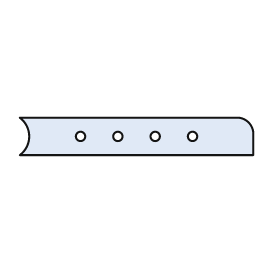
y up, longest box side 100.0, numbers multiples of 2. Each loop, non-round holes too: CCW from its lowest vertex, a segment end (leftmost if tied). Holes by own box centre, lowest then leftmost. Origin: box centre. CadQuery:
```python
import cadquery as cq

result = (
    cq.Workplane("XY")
    .moveTo(-50.0, -8.0)
    .lineTo(50.0, -8.0)
    .lineTo(50.0, 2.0)
    .threePointArc((48.0, 6.0), (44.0, 8.0))
    .lineTo(-50.0, 8.0)
    .threePointArc((-46.0, 0.0), (-50.0, -8.0))
    .close()
    .moveTo(-24.0, 0.0)
    .circle(2.0)
    .moveTo(-8.0, 0.0)
    .circle(2.0)
    .moveTo(8.0, 0.0)
    .circle(2.0)
    .moveTo(24.0, 0.0)
    .circle(2.0)
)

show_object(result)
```